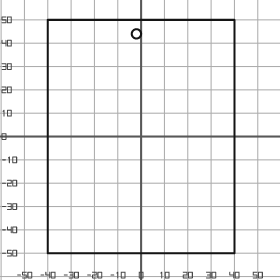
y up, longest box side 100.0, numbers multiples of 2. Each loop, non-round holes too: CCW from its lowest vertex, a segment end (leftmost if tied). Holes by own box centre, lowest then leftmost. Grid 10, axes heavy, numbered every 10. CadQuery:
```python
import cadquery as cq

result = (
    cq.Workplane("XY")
    .moveTo(-40.0, -50.0)
    .lineTo(40.0, -50.0)
    .lineTo(40.0, 50.0)
    .lineTo(-40.0, 50.0)
    .close()
    .moveTo(-2.0, 44.0)
    .circle(2.0)
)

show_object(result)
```